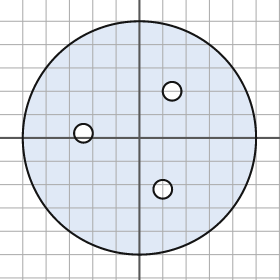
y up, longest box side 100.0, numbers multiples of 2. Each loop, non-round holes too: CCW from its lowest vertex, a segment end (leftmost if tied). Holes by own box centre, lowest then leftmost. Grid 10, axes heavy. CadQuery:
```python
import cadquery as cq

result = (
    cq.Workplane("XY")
    .moveTo(0.0, 0.0)
    .circle(50.0)
    .moveTo(10.0, -22.0)
    .circle(4.0)
    .moveTo(-24.0, 2.0)
    .circle(4.0)
    .moveTo(14.0, 20.0)
    .circle(4.0)
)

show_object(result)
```